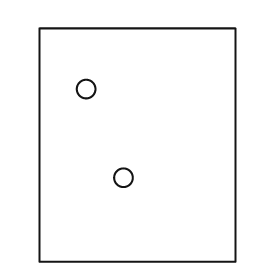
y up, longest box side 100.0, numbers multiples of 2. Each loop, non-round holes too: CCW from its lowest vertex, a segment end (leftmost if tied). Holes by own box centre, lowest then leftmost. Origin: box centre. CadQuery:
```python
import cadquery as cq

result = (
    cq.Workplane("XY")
    .moveTo(-42.0, -50.0)
    .lineTo(42.0, -50.0)
    .lineTo(42.0, 50.0)
    .lineTo(-42.0, 50.0)
    .close()
    .moveTo(-6.0, -14.0)
    .circle(4.0)
    .moveTo(-22.0, 24.0)
    .circle(4.0)
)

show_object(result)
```